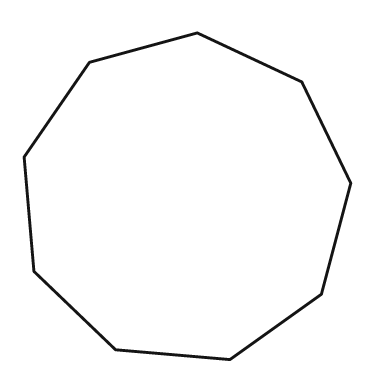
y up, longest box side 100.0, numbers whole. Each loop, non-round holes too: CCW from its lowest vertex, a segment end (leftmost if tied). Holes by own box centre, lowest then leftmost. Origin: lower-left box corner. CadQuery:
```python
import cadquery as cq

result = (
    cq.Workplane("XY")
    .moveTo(63.0, 0.0)
    .lineTo(91.0, 20.0)
    .lineTo(100.0, 54.0)
    .lineTo(85.0, 85.0)
    .lineTo(53.0, 100.0)
    .lineTo(20.0, 91.0)
    .lineTo(0.0, 62.0)
    .lineTo(3.0, 27.0)
    .lineTo(28.0, 3.0)
    .close()
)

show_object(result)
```